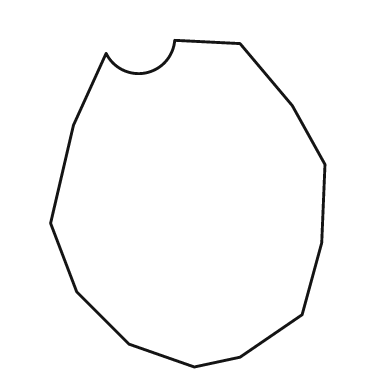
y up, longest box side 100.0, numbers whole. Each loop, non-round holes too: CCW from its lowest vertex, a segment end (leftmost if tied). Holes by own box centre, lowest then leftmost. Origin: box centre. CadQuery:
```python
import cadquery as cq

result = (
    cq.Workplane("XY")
    .moveTo(2.0, -50.0)
    .lineTo(16.0, -47.0)
    .lineTo(35.0, -34.0)
    .lineTo(41.0, -12.0)
    .lineTo(42.0, 12.0)
    .lineTo(32.0, 30.0)
    .lineTo(16.0, 49.0)
    .lineTo(-4.0, 50.0)
    .threePointArc((-13.0, 40.0), (-25.0, 46.0))
    .lineTo(-35.0, 24.0)
    .lineTo(-42.0, -6.0)
    .lineTo(-34.0, -27.0)
    .lineTo(-18.0, -43.0)
    .close()
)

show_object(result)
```